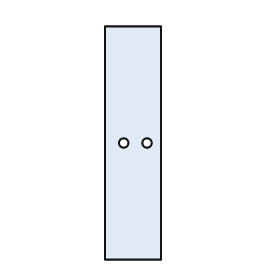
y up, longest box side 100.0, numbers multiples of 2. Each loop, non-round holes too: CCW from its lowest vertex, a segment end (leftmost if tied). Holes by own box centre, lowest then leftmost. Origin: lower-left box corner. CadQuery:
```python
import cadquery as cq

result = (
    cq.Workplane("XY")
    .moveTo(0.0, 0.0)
    .lineTo(24.0, 0.0)
    .lineTo(24.0, 100.0)
    .lineTo(0.0, 100.0)
    .close()
    .moveTo(8.0, 50.0)
    .circle(2.0)
    .moveTo(18.0, 50.0)
    .circle(2.0)
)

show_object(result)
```